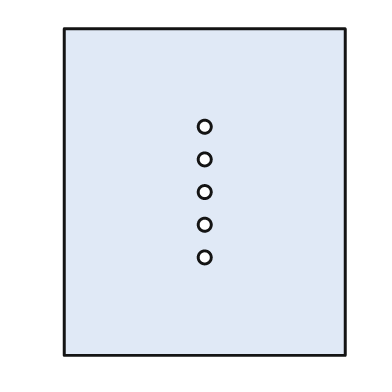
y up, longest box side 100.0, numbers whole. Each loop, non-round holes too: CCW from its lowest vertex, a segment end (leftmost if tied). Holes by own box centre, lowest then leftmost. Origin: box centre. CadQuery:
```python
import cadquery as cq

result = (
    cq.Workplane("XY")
    .moveTo(-43.0, -50.0)
    .lineTo(43.0, -50.0)
    .lineTo(43.0, 50.0)
    .lineTo(-43.0, 50.0)
    .close()
    .moveTo(0.0, -20.0)
    .circle(2.0)
    .moveTo(0.0, -10.0)
    .circle(2.0)
    .moveTo(0.0, 0.0)
    .circle(2.0)
    .moveTo(0.0, 10.0)
    .circle(2.0)
    .moveTo(0.0, 20.0)
    .circle(2.0)
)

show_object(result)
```